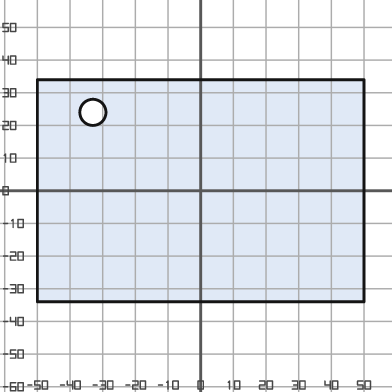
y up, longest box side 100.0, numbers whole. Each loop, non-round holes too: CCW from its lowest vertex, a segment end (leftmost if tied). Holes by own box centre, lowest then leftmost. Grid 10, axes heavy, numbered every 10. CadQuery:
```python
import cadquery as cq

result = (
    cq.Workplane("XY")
    .moveTo(-50.0, -34.0)
    .lineTo(50.0, -34.0)
    .lineTo(50.0, 34.0)
    .lineTo(-50.0, 34.0)
    .close()
    .moveTo(-33.0, 24.0)
    .circle(4.0)
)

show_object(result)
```